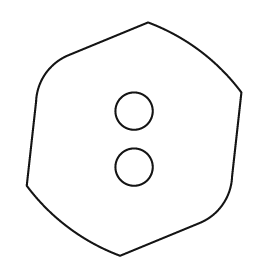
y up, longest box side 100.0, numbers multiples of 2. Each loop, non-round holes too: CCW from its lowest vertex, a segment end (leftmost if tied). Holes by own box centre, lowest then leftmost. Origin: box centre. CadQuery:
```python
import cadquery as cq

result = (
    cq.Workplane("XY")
    .moveTo(-6.0, -50.0)
    .lineTo(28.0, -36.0)
    .threePointArc((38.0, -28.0), (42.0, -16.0))
    .lineTo(46.0, 20.0)
    .threePointArc((28.0, 38.0), (6.0, 50.0))
    .lineTo(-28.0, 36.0)
    .threePointArc((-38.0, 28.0), (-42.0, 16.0))
    .lineTo(-46.0, -20.0)
    .threePointArc((-28.0, -38.0), (-6.0, -50.0))
    .close()
    .moveTo(0.0, -12.0)
    .circle(8.0)
    .moveTo(0.0, 12.0)
    .circle(8.0)
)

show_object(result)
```